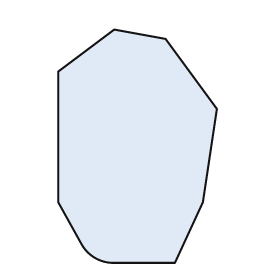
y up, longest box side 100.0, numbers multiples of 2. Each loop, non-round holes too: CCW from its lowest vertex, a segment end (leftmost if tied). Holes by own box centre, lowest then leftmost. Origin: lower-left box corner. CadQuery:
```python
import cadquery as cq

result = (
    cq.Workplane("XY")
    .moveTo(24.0, 0.0)
    .lineTo(50.0, 0.0)
    .lineTo(62.0, 26.0)
    .lineTo(68.0, 66.0)
    .lineTo(46.0, 96.0)
    .lineTo(24.0, 100.0)
    .lineTo(0.0, 82.0)
    .lineTo(0.0, 26.0)
    .lineTo(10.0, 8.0)
    .threePointArc((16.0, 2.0), (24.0, 0.0))
    .close()
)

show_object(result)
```